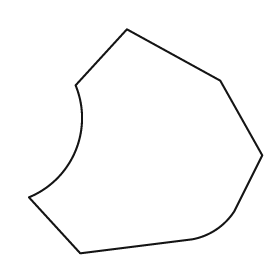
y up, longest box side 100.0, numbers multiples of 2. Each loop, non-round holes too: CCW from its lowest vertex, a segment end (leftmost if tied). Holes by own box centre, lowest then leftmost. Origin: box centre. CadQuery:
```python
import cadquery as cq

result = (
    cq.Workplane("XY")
    .moveTo(-28.0, -48.0)
    .lineTo(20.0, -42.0)
    .threePointArc((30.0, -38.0), (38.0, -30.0))
    .lineTo(50.0, -6.0)
    .lineTo(32.0, 26.0)
    .lineTo(-8.0, 48.0)
    .lineTo(-30.0, 24.0)
    .threePointArc((-30.0, -4.0), (-50.0, -24.0))
    .close()
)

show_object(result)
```